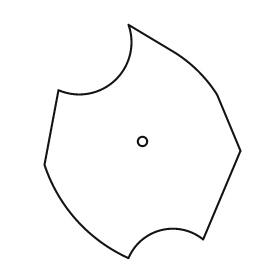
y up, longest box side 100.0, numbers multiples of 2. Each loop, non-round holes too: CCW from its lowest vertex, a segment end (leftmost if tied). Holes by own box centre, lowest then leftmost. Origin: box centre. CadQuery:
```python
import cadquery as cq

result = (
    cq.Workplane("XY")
    .moveTo(-6.0, -50.0)
    .threePointArc((8.0, -38.0), (26.0, -42.0))
    .lineTo(42.0, -4.0)
    .lineTo(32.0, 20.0)
    .threePointArc((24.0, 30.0), (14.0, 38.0))
    .lineTo(-6.0, 50.0)
    .threePointArc((-12.0, 26.0), (-36.0, 22.0))
    .lineTo(-42.0, -10.0)
    .threePointArc((-28.0, -34.0), (-6.0, -50.0))
    .close()
    .moveTo(0.0, 0.0)
    .circle(2.0)
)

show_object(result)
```